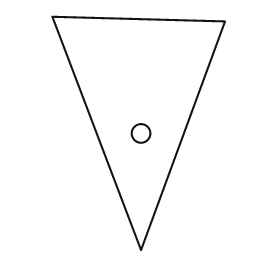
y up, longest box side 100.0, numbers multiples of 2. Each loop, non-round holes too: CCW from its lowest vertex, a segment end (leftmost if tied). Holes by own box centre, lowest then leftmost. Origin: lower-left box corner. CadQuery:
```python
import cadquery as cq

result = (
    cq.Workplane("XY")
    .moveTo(38.0, 0.0)
    .lineTo(74.0, 98.0)
    .lineTo(0.0, 100.0)
    .close()
    .moveTo(38.0, 50.0)
    .circle(4.0)
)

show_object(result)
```